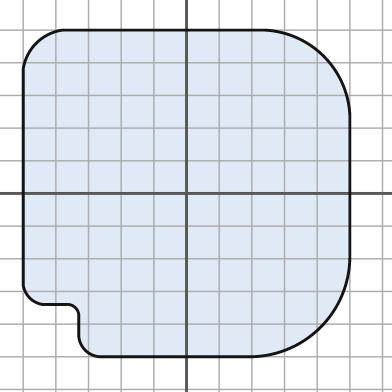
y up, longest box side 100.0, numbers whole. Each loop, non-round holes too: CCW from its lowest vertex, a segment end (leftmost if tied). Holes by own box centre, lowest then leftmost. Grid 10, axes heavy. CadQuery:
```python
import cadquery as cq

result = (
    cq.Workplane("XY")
    .moveTo(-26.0, -50.0)
    .lineTo(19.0, -50.0)
    .threePointArc((41.0, -41.0), (50.0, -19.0))
    .lineTo(50.0, 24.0)
    .threePointArc((42.0, 42.0), (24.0, 50.0))
    .lineTo(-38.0, 50.0)
    .threePointArc((-46.0, 46.0), (-50.0, 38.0))
    .lineTo(-50.0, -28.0)
    .threePointArc((-48.0, -32.0), (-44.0, -34.0))
    .lineTo(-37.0, -34.0)
    .threePointArc((-34.0, -35.0), (-33.0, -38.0))
    .lineTo(-33.0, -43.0)
    .threePointArc((-31.0, -48.0), (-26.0, -50.0))
    .close()
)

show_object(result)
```